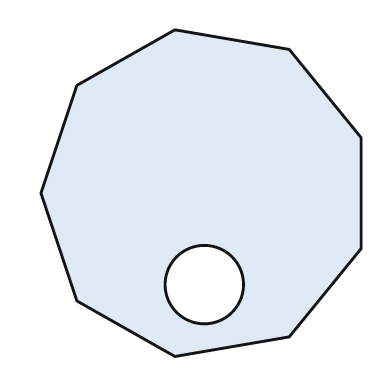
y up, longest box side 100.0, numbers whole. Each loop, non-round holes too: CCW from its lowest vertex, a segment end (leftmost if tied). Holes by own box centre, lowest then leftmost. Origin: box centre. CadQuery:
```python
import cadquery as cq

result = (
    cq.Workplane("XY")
    .moveTo(-8.0, -50.0)
    .lineTo(27.0, -44.0)
    .lineTo(49.0, -17.0)
    .lineTo(49.0, 17.0)
    .lineTo(27.0, 44.0)
    .lineTo(-8.0, 50.0)
    .lineTo(-38.0, 33.0)
    .lineTo(-49.0, 0.0)
    .lineTo(-38.0, -33.0)
    .close()
    .moveTo(1.0, -28.0)
    .circle(12.0)
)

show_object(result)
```